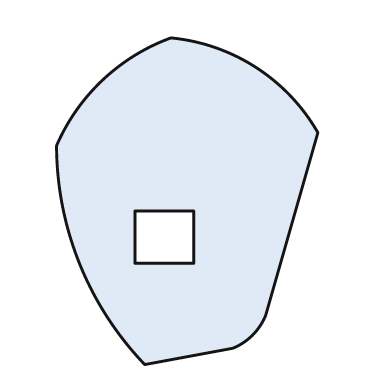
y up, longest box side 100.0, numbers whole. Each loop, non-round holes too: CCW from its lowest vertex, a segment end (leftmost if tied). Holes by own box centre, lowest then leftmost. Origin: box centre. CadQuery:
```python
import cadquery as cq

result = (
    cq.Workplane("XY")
    .moveTo(-13.0, -50.0)
    .lineTo(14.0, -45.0)
    .threePointArc((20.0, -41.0), (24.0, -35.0))
    .lineTo(40.0, 21.0)
    .threePointArc((21.0, 41.0), (-5.0, 50.0))
    .threePointArc((-26.0, 37.0), (-40.0, 17.0))
    .threePointArc((-33.0, -19.0), (-13.0, -50.0))
    .close()
    .moveTo(-16.0, -19.0)
    .lineTo(2.0, -19.0)
    .lineTo(2.0, -3.0)
    .lineTo(-16.0, -3.0)
    .close()
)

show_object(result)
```